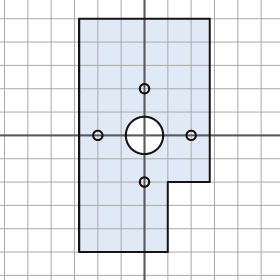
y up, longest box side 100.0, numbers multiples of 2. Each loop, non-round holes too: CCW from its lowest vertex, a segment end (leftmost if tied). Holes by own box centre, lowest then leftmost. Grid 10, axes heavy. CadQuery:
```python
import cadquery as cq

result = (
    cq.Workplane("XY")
    .moveTo(-28.0, -50.0)
    .lineTo(10.0, -50.0)
    .lineTo(10.0, -20.0)
    .lineTo(28.0, -20.0)
    .lineTo(28.0, 50.0)
    .lineTo(-28.0, 50.0)
    .close()
    .moveTo(0.0, -20.0)
    .circle(2.0)
    .moveTo(-20.0, 0.0)
    .circle(2.0)
    .moveTo(0.0, 0.0)
    .circle(8.0)
    .moveTo(20.0, 0.0)
    .circle(2.0)
    .moveTo(0.0, 20.0)
    .circle(2.0)
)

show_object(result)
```